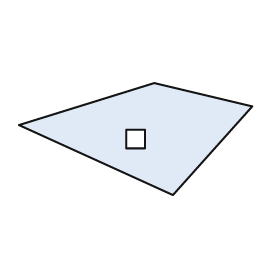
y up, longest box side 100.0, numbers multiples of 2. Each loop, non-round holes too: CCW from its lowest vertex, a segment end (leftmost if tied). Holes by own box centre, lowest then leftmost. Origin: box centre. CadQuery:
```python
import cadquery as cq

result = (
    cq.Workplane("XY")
    .moveTo(16.0, -24.0)
    .lineTo(50.0, 14.0)
    .lineTo(8.0, 24.0)
    .lineTo(-50.0, 6.0)
    .close()
    .moveTo(-4.0, -4.0)
    .lineTo(4.0, -4.0)
    .lineTo(4.0, 4.0)
    .lineTo(-4.0, 4.0)
    .close()
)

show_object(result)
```